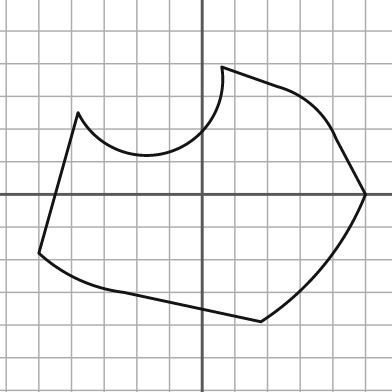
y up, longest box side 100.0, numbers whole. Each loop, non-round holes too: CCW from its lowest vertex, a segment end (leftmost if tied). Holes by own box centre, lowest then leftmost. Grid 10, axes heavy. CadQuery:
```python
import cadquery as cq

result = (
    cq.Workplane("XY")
    .moveTo(18.0, -39.0)
    .threePointArc((37.0, -22.0), (50.0, 0.0))
    .lineTo(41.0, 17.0)
    .threePointArc((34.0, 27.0), (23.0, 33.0))
    .lineTo(6.0, 39.0)
    .threePointArc((-10.0, 13.0), (-38.0, 25.0))
    .lineTo(-50.0, -18.0)
    .threePointArc((-38.0, -26.0), (-24.0, -30.0))
    .close()
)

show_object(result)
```